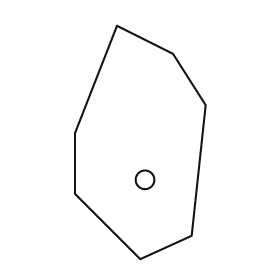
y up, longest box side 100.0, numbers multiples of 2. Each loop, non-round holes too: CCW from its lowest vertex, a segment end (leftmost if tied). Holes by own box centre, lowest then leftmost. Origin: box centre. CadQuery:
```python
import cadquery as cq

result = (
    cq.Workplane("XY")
    .moveTo(0.0, -50.0)
    .lineTo(22.0, -40.0)
    .lineTo(28.0, 16.0)
    .lineTo(14.0, 38.0)
    .lineTo(-10.0, 50.0)
    .lineTo(-28.0, 4.0)
    .lineTo(-28.0, -22.0)
    .close()
    .moveTo(2.0, -16.0)
    .circle(4.0)
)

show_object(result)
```